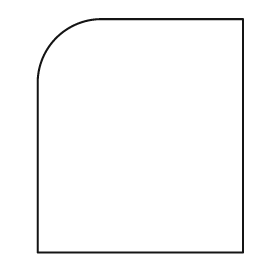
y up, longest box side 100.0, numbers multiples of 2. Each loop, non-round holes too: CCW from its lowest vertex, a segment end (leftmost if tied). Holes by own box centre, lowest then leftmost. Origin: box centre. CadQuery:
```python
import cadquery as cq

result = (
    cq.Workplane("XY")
    .moveTo(-44.0, -50.0)
    .lineTo(44.0, -50.0)
    .lineTo(44.0, 50.0)
    .lineTo(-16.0, 50.0)
    .threePointArc((-36.0, 42.0), (-44.0, 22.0))
    .close()
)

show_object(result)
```